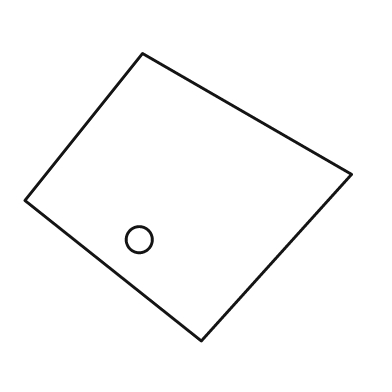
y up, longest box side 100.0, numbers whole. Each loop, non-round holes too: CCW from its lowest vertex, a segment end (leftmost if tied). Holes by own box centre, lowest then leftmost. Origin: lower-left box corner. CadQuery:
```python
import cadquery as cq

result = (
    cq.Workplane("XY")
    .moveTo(54.0, 0.0)
    .lineTo(100.0, 51.0)
    .lineTo(36.0, 88.0)
    .lineTo(0.0, 43.0)
    .close()
    .moveTo(35.0, 31.0)
    .circle(4.0)
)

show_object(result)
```